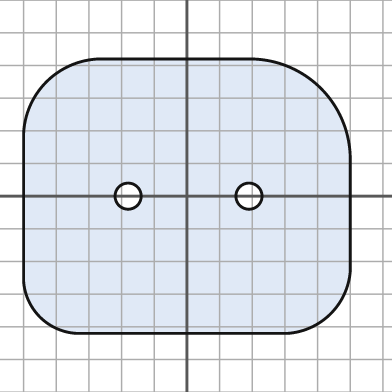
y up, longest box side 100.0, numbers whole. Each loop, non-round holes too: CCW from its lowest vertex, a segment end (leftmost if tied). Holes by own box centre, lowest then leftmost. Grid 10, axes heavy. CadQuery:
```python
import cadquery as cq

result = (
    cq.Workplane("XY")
    .moveTo(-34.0, -42.0)
    .lineTo(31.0, -42.0)
    .threePointArc((44.0, -36.0), (50.0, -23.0))
    .lineTo(50.0, 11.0)
    .threePointArc((41.0, 33.0), (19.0, 42.0))
    .lineTo(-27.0, 42.0)
    .threePointArc((-43.0, 35.0), (-50.0, 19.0))
    .lineTo(-50.0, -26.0)
    .threePointArc((-45.0, -37.0), (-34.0, -42.0))
    .close()
    .moveTo(-18.0, 0.0)
    .circle(4.0)
    .moveTo(19.0, 0.0)
    .circle(4.0)
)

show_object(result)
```